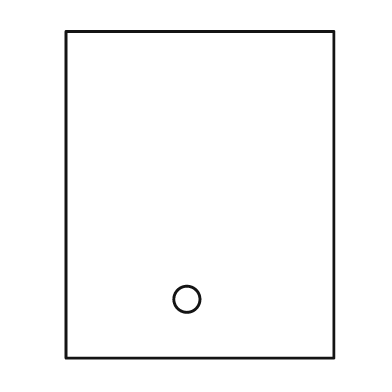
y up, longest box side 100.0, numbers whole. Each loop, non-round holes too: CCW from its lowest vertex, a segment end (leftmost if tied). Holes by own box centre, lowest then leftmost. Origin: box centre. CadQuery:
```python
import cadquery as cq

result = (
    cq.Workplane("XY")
    .moveTo(-41.0, -50.0)
    .lineTo(41.0, -50.0)
    .lineTo(41.0, 50.0)
    .lineTo(-41.0, 50.0)
    .close()
    .moveTo(-4.0, -32.0)
    .circle(4.0)
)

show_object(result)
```